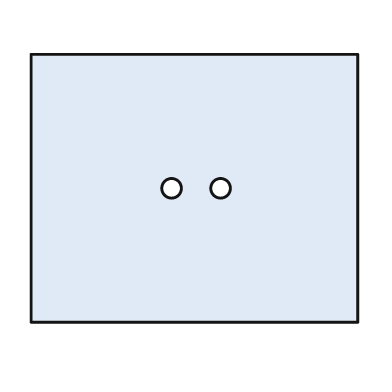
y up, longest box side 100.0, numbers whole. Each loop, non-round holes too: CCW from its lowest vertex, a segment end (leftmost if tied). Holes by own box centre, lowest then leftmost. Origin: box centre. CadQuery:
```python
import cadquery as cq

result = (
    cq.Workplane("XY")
    .moveTo(-50.0, -41.0)
    .lineTo(50.0, -41.0)
    .lineTo(50.0, 41.0)
    .lineTo(-50.0, 41.0)
    .close()
    .moveTo(-7.0, 0.0)
    .circle(3.0)
    .moveTo(8.0, 0.0)
    .circle(3.0)
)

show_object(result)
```